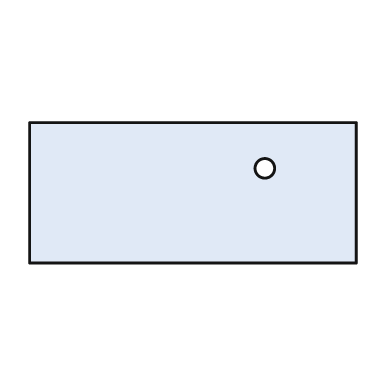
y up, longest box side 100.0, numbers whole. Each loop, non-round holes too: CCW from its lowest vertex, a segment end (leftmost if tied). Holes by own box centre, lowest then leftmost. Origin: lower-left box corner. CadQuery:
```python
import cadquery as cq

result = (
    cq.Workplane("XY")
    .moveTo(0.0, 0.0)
    .lineTo(100.0, 0.0)
    .lineTo(100.0, 43.0)
    .lineTo(0.0, 43.0)
    .close()
    .moveTo(72.0, 29.0)
    .circle(3.0)
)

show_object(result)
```